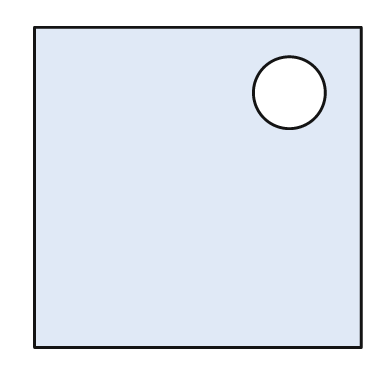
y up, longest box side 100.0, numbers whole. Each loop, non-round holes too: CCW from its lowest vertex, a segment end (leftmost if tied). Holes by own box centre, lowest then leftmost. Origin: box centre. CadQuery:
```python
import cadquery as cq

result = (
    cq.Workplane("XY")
    .moveTo(-50.0, -49.0)
    .lineTo(50.0, -49.0)
    .lineTo(50.0, 49.0)
    .lineTo(-50.0, 49.0)
    .close()
    .moveTo(28.0, 29.0)
    .circle(11.0)
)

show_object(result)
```